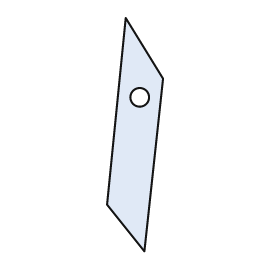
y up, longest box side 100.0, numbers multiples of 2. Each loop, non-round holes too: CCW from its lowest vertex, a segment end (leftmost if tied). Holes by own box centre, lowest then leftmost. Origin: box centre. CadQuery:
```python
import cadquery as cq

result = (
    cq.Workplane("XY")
    .moveTo(4.0, -50.0)
    .lineTo(12.0, 24.0)
    .lineTo(-4.0, 50.0)
    .lineTo(-12.0, -30.0)
    .close()
    .moveTo(2.0, 16.0)
    .circle(4.0)
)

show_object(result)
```